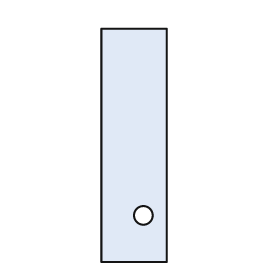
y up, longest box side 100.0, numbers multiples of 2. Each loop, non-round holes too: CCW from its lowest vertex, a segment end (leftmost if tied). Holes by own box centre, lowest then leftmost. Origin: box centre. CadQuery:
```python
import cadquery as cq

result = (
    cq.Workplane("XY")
    .moveTo(-14.0, -50.0)
    .lineTo(14.0, -50.0)
    .lineTo(14.0, 50.0)
    .lineTo(-14.0, 50.0)
    .close()
    .moveTo(4.0, -30.0)
    .circle(4.0)
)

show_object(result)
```